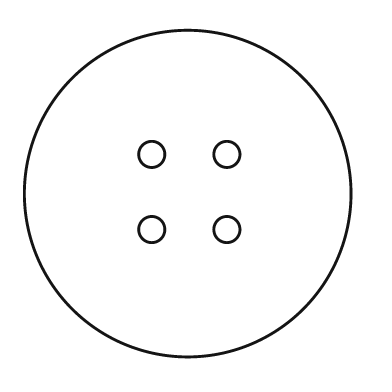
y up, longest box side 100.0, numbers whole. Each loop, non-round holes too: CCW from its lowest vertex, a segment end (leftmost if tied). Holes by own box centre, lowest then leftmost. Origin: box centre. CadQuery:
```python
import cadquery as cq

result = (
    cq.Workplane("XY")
    .moveTo(0.0, 0.0)
    .circle(50.0)
    .moveTo(-11.0, -11.0)
    .circle(4.0)
    .moveTo(12.0, -11.0)
    .circle(4.0)
    .moveTo(-11.0, 12.0)
    .circle(4.0)
    .moveTo(12.0, 12.0)
    .circle(4.0)
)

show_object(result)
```